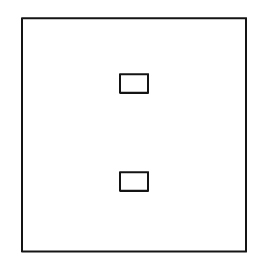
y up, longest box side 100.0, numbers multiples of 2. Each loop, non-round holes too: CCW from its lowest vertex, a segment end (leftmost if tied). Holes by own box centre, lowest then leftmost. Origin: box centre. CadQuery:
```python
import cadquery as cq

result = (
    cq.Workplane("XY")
    .moveTo(-48.0, -50.0)
    .lineTo(48.0, -50.0)
    .lineTo(48.0, 50.0)
    .lineTo(-48.0, 50.0)
    .close()
    .moveTo(-6.0, -24.0)
    .lineTo(6.0, -24.0)
    .lineTo(6.0, -16.0)
    .lineTo(-6.0, -16.0)
    .close()
    .moveTo(-6.0, 18.0)
    .lineTo(6.0, 18.0)
    .lineTo(6.0, 26.0)
    .lineTo(-6.0, 26.0)
    .close()
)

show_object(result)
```